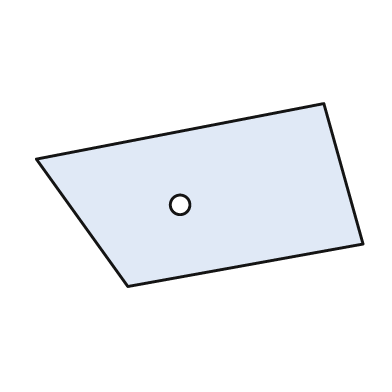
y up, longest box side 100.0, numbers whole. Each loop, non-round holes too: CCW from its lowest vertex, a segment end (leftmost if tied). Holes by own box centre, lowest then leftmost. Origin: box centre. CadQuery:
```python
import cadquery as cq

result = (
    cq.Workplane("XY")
    .moveTo(-22.0, -28.0)
    .lineTo(50.0, -15.0)
    .lineTo(38.0, 28.0)
    .lineTo(-50.0, 11.0)
    .close()
    .moveTo(-6.0, -3.0)
    .circle(3.0)
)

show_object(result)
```